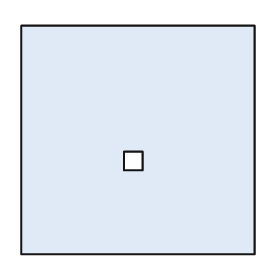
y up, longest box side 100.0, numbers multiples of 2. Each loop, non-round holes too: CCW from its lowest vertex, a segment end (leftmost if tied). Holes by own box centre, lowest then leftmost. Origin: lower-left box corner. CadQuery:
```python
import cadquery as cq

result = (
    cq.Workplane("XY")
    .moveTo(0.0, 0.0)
    .lineTo(100.0, 0.0)
    .lineTo(100.0, 98.0)
    .lineTo(0.0, 98.0)
    .close()
    .moveTo(44.0, 36.0)
    .lineTo(52.0, 36.0)
    .lineTo(52.0, 44.0)
    .lineTo(44.0, 44.0)
    .close()
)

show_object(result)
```